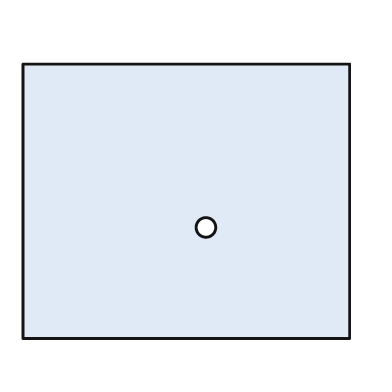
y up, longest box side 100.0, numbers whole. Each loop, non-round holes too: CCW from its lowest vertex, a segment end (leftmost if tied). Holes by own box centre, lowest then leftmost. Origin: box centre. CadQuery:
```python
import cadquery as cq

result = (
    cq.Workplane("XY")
    .moveTo(-50.0, -42.0)
    .lineTo(50.0, -42.0)
    .lineTo(50.0, 42.0)
    .lineTo(-50.0, 42.0)
    .close()
    .moveTo(6.0, -8.0)
    .circle(3.0)
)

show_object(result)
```